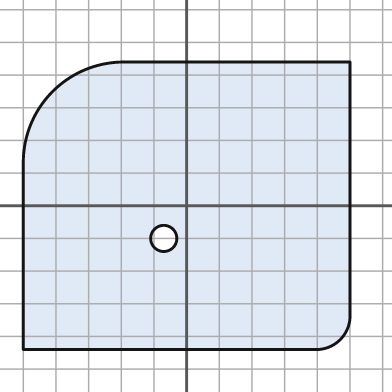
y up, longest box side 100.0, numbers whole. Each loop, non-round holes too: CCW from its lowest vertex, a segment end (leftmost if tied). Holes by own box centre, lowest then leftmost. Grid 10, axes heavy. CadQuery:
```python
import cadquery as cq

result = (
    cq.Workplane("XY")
    .moveTo(-50.0, -44.0)
    .lineTo(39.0, -44.0)
    .threePointArc((47.0, -41.0), (50.0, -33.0))
    .lineTo(50.0, 44.0)
    .lineTo(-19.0, 44.0)
    .threePointArc((-41.0, 35.0), (-50.0, 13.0))
    .close()
    .moveTo(-7.0, -10.0)
    .circle(4.0)
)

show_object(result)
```